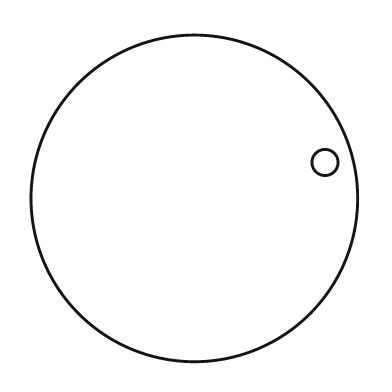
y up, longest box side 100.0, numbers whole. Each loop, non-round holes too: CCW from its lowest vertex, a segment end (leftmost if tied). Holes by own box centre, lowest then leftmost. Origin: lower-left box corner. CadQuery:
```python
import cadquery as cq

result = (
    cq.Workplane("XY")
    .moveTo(50.0, 50.0)
    .circle(50.0)
    .moveTo(90.0, 61.0)
    .circle(4.0)
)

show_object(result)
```